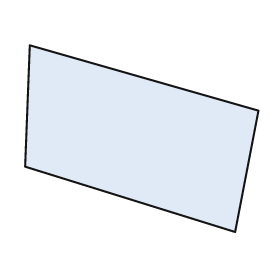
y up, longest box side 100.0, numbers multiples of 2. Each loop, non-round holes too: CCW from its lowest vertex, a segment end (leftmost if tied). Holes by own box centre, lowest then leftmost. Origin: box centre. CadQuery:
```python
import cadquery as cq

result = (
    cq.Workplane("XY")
    .moveTo(40.0, -40.0)
    .lineTo(50.0, 12.0)
    .lineTo(-48.0, 40.0)
    .lineTo(-50.0, -12.0)
    .close()
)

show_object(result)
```